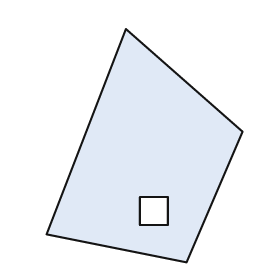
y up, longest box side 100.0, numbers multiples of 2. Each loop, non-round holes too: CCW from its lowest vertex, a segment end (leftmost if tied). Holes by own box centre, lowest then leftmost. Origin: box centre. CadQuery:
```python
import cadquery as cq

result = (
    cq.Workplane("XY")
    .moveTo(18.0, -50.0)
    .lineTo(42.0, 6.0)
    .lineTo(-8.0, 50.0)
    .lineTo(-42.0, -38.0)
    .close()
    .moveTo(-2.0, -34.0)
    .lineTo(10.0, -34.0)
    .lineTo(10.0, -22.0)
    .lineTo(-2.0, -22.0)
    .close()
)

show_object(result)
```